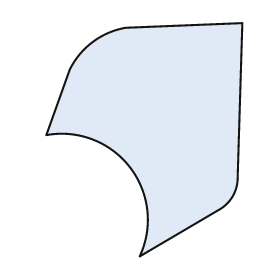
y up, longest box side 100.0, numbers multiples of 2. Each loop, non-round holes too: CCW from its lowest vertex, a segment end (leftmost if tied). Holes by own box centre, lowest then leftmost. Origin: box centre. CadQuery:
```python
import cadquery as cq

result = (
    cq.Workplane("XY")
    .moveTo(-2.0, -50.0)
    .lineTo(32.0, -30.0)
    .threePointArc((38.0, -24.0), (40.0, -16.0))
    .lineTo(42.0, 50.0)
    .lineTo(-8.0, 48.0)
    .threePointArc((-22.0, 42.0), (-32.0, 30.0))
    .lineTo(-42.0, 2.0)
    .threePointArc((-6.0, -12.0), (-2.0, -50.0))
    .close()
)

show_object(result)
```